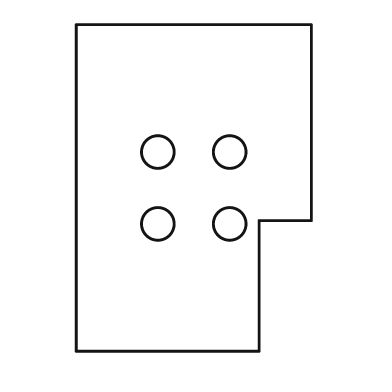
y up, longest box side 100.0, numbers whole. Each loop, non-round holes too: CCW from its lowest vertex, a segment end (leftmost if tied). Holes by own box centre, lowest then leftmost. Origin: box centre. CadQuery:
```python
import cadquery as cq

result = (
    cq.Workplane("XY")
    .moveTo(-36.0, -50.0)
    .lineTo(20.0, -50.0)
    .lineTo(20.0, -10.0)
    .lineTo(36.0, -10.0)
    .lineTo(36.0, 50.0)
    .lineTo(-36.0, 50.0)
    .close()
    .moveTo(-11.0, -11.0)
    .circle(5.0)
    .moveTo(11.0, -11.0)
    .circle(5.0)
    .moveTo(-11.0, 11.0)
    .circle(5.0)
    .moveTo(11.0, 11.0)
    .circle(5.0)
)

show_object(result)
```